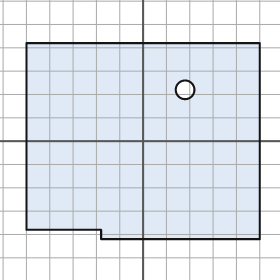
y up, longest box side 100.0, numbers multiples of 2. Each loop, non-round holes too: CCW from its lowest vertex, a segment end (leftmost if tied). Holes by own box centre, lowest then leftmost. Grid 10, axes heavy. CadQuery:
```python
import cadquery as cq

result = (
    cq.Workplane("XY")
    .moveTo(-18.0, -42.0)
    .lineTo(50.0, -42.0)
    .lineTo(50.0, 42.0)
    .lineTo(-50.0, 42.0)
    .lineTo(-50.0, -38.0)
    .lineTo(-18.0, -38.0)
    .close()
    .moveTo(18.0, 22.0)
    .circle(4.0)
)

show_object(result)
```